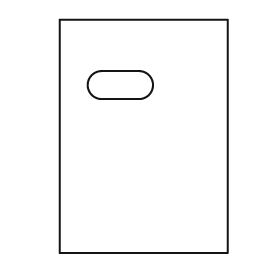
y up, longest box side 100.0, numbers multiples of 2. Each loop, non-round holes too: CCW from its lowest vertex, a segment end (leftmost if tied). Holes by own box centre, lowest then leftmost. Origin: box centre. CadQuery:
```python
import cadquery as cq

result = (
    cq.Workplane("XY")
    .moveTo(-36.0, -50.0)
    .lineTo(36.0, -50.0)
    .lineTo(36.0, 50.0)
    .lineTo(-36.0, 50.0)
    .close()
    .moveTo(-18.0, 16.0)
    .lineTo(-2.0, 16.0)
    .threePointArc((4.0, 22.0), (-2.0, 28.0))
    .lineTo(-18.0, 28.0)
    .threePointArc((-24.0, 22.0), (-18.0, 16.0))
    .close()
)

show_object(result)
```